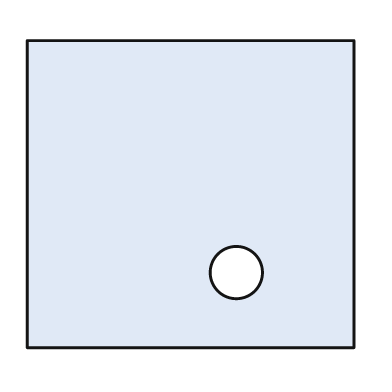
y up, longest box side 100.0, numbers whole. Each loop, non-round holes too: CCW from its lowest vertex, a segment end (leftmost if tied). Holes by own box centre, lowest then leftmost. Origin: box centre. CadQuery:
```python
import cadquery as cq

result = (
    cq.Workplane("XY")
    .moveTo(-50.0, -47.0)
    .lineTo(50.0, -47.0)
    .lineTo(50.0, 47.0)
    .lineTo(-50.0, 47.0)
    .close()
    .moveTo(14.0, -24.0)
    .circle(8.0)
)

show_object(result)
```